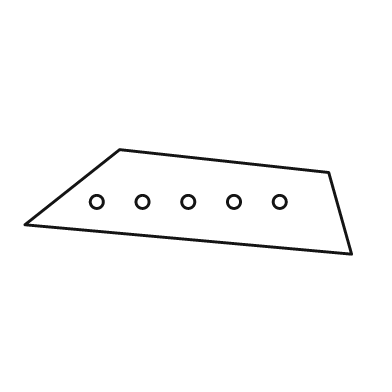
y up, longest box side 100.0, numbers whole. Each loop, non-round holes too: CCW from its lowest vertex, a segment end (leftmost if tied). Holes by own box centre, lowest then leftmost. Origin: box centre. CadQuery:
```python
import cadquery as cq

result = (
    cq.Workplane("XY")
    .moveTo(50.0, -16.0)
    .lineTo(43.0, 9.0)
    .lineTo(-21.0, 16.0)
    .lineTo(-50.0, -7.0)
    .close()
    .moveTo(-28.0, 0.0)
    .circle(2.0)
    .moveTo(-14.0, 0.0)
    .circle(2.0)
    .moveTo(0.0, 0.0)
    .circle(2.0)
    .moveTo(14.0, 0.0)
    .circle(2.0)
    .moveTo(28.0, 0.0)
    .circle(2.0)
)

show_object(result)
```